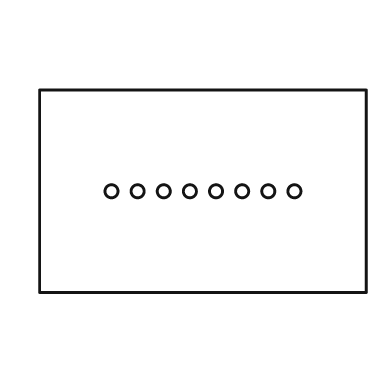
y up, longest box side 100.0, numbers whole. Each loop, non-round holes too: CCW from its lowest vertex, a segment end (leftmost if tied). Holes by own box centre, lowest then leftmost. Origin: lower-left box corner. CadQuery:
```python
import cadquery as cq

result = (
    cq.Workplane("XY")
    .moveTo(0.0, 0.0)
    .lineTo(100.0, 0.0)
    .lineTo(100.0, 62.0)
    .lineTo(0.0, 62.0)
    .close()
    .moveTo(22.0, 31.0)
    .circle(2.0)
    .moveTo(30.0, 31.0)
    .circle(2.0)
    .moveTo(38.0, 31.0)
    .circle(2.0)
    .moveTo(46.0, 31.0)
    .circle(2.0)
    .moveTo(54.0, 31.0)
    .circle(2.0)
    .moveTo(62.0, 31.0)
    .circle(2.0)
    .moveTo(70.0, 31.0)
    .circle(2.0)
    .moveTo(78.0, 31.0)
    .circle(2.0)
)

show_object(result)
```